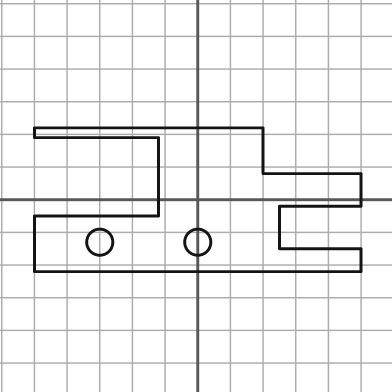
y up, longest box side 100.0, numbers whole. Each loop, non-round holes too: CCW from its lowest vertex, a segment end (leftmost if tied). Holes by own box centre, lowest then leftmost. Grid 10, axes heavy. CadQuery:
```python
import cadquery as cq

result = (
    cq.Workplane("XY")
    .moveTo(-50.0, -22.0)
    .lineTo(50.0, -22.0)
    .lineTo(50.0, -15.0)
    .lineTo(25.0, -15.0)
    .lineTo(25.0, -2.0)
    .lineTo(50.0, -2.0)
    .lineTo(50.0, 8.0)
    .lineTo(20.0, 8.0)
    .lineTo(20.0, 22.0)
    .lineTo(-50.0, 22.0)
    .lineTo(-50.0, 19.0)
    .lineTo(-12.0, 19.0)
    .lineTo(-12.0, -5.0)
    .lineTo(-50.0, -5.0)
    .close()
    .moveTo(-30.0, -13.0)
    .circle(4.0)
    .moveTo(0.0, -13.0)
    .circle(4.0)
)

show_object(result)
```